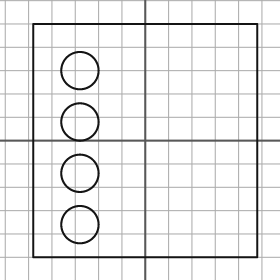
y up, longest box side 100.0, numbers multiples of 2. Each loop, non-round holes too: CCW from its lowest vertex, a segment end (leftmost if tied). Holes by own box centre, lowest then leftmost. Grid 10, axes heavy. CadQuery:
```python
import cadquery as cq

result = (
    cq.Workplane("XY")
    .moveTo(-48.0, -50.0)
    .lineTo(48.0, -50.0)
    .lineTo(48.0, 50.0)
    .lineTo(-48.0, 50.0)
    .close()
    .moveTo(-28.0, -36.0)
    .circle(8.0)
    .moveTo(-28.0, -14.0)
    .circle(8.0)
    .moveTo(-28.0, 8.0)
    .circle(8.0)
    .moveTo(-28.0, 30.0)
    .circle(8.0)
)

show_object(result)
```